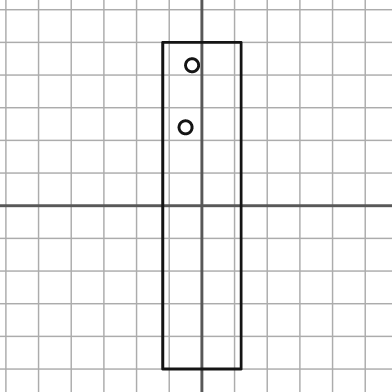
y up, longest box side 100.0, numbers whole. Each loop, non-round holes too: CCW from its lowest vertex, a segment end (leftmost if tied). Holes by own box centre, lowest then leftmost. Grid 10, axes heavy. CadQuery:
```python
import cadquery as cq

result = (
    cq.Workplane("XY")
    .moveTo(-12.0, -50.0)
    .lineTo(12.0, -50.0)
    .lineTo(12.0, 50.0)
    .lineTo(-12.0, 50.0)
    .close()
    .moveTo(-5.0, 24.0)
    .circle(2.0)
    .moveTo(-3.0, 43.0)
    .circle(2.0)
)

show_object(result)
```